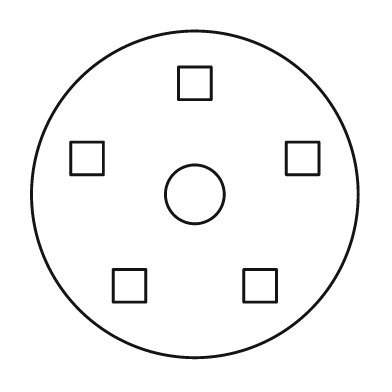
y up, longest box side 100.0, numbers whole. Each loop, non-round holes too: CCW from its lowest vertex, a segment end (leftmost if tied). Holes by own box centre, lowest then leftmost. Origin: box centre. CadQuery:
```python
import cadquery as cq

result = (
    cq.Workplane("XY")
    .moveTo(0.0, 0.0)
    .circle(50.0)
    .moveTo(-25.0, -33.0)
    .lineTo(-15.0, -33.0)
    .lineTo(-15.0, -23.0)
    .lineTo(-25.0, -23.0)
    .close()
    .moveTo(15.0, -33.0)
    .lineTo(25.0, -33.0)
    .lineTo(25.0, -23.0)
    .lineTo(15.0, -23.0)
    .close()
    .moveTo(0.0, 0.0)
    .circle(9.0)
    .moveTo(-38.0, 6.0)
    .lineTo(-28.0, 6.0)
    .lineTo(-28.0, 16.0)
    .lineTo(-38.0, 16.0)
    .close()
    .moveTo(28.0, 6.0)
    .lineTo(38.0, 6.0)
    .lineTo(38.0, 16.0)
    .lineTo(28.0, 16.0)
    .close()
    .moveTo(-5.0, 29.0)
    .lineTo(5.0, 29.0)
    .lineTo(5.0, 39.0)
    .lineTo(-5.0, 39.0)
    .close()
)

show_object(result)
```